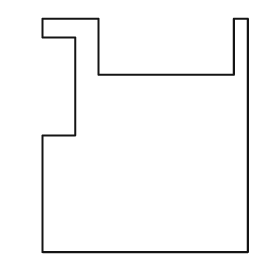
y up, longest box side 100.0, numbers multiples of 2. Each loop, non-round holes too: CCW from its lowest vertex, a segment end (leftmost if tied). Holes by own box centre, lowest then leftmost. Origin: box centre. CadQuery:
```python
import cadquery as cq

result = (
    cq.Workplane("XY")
    .moveTo(-44.0, -50.0)
    .lineTo(44.0, -50.0)
    .lineTo(44.0, 50.0)
    .lineTo(38.0, 50.0)
    .lineTo(38.0, 26.0)
    .lineTo(-20.0, 26.0)
    .lineTo(-20.0, 50.0)
    .lineTo(-44.0, 50.0)
    .lineTo(-44.0, 42.0)
    .lineTo(-30.0, 42.0)
    .lineTo(-30.0, 0.0)
    .lineTo(-44.0, 0.0)
    .close()
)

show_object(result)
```